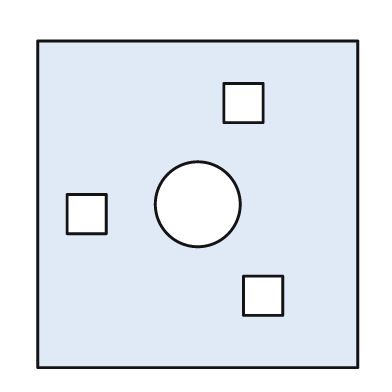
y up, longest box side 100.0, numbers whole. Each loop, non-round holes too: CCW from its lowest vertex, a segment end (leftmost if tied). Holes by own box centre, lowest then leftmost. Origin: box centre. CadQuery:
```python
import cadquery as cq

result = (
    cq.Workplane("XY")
    .moveTo(-49.0, -50.0)
    .lineTo(49.0, -50.0)
    .lineTo(49.0, 50.0)
    .lineTo(-49.0, 50.0)
    .close()
    .moveTo(14.0, -34.0)
    .lineTo(26.0, -34.0)
    .lineTo(26.0, -22.0)
    .lineTo(14.0, -22.0)
    .close()
    .moveTo(-40.0, -9.0)
    .lineTo(-28.0, -9.0)
    .lineTo(-28.0, 3.0)
    .lineTo(-40.0, 3.0)
    .close()
    .moveTo(0.0, 0.0)
    .circle(13.0)
    .moveTo(8.0, 25.0)
    .lineTo(20.0, 25.0)
    .lineTo(20.0, 37.0)
    .lineTo(8.0, 37.0)
    .close()
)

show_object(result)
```